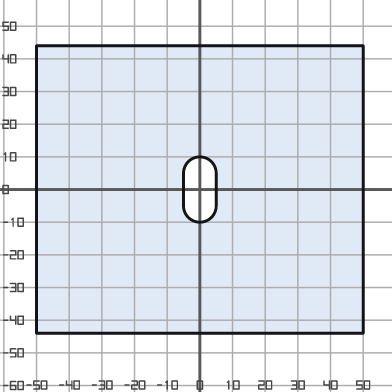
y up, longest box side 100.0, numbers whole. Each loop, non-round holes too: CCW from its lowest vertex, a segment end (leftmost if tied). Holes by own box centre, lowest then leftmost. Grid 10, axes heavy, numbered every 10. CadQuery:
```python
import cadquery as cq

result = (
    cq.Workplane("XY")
    .moveTo(-50.0, -44.0)
    .lineTo(50.0, -44.0)
    .lineTo(50.0, 44.0)
    .lineTo(-50.0, 44.0)
    .close()
    .moveTo(-5.0, -5.0)
    .threePointArc((0.0, -10.0), (5.0, -5.0))
    .lineTo(5.0, 5.0)
    .threePointArc((0.0, 10.0), (-5.0, 5.0))
    .close()
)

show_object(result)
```